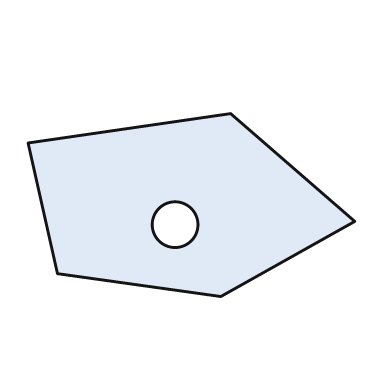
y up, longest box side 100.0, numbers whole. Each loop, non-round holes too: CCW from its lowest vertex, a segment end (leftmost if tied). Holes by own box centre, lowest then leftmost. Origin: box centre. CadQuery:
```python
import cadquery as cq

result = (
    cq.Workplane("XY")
    .moveTo(9.0, -28.0)
    .lineTo(50.0, -5.0)
    .lineTo(12.0, 28.0)
    .lineTo(-50.0, 19.0)
    .lineTo(-41.0, -21.0)
    .close()
    .moveTo(-5.0, -6.0)
    .circle(7.0)
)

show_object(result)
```